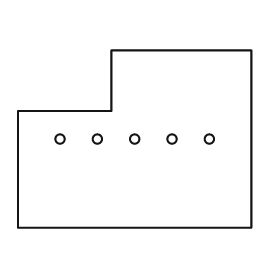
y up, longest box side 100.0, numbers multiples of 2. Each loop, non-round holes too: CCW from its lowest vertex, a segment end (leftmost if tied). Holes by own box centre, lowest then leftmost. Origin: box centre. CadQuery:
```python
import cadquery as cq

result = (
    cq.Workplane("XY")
    .moveTo(-50.0, -38.0)
    .lineTo(50.0, -38.0)
    .lineTo(50.0, 38.0)
    .lineTo(-10.0, 38.0)
    .lineTo(-10.0, 12.0)
    .lineTo(-50.0, 12.0)
    .close()
    .moveTo(-32.0, 0.0)
    .circle(2.0)
    .moveTo(-16.0, 0.0)
    .circle(2.0)
    .moveTo(0.0, 0.0)
    .circle(2.0)
    .moveTo(16.0, 0.0)
    .circle(2.0)
    .moveTo(32.0, 0.0)
    .circle(2.0)
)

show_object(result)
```